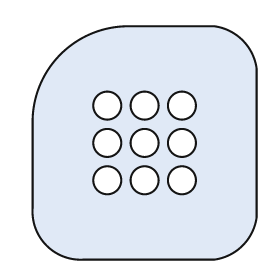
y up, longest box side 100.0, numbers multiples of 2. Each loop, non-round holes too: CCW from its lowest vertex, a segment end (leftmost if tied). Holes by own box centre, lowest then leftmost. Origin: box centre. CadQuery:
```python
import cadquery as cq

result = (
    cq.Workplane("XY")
    .moveTo(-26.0, -50.0)
    .lineTo(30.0, -50.0)
    .threePointArc((42.0, -44.0), (48.0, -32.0))
    .lineTo(48.0, 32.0)
    .threePointArc((42.0, 44.0), (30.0, 50.0))
    .lineTo(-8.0, 50.0)
    .threePointArc((-36.0, 38.0), (-48.0, 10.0))
    .lineTo(-48.0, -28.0)
    .threePointArc((-42.0, -44.0), (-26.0, -50.0))
    .close()
    .moveTo(-16.0, -16.0)
    .circle(6.0)
    .moveTo(0.0, -16.0)
    .circle(6.0)
    .moveTo(16.0, -16.0)
    .circle(6.0)
    .moveTo(-16.0, 0.0)
    .circle(6.0)
    .moveTo(0.0, 0.0)
    .circle(6.0)
    .moveTo(16.0, 0.0)
    .circle(6.0)
    .moveTo(-16.0, 16.0)
    .circle(6.0)
    .moveTo(0.0, 16.0)
    .circle(6.0)
    .moveTo(16.0, 16.0)
    .circle(6.0)
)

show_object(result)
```